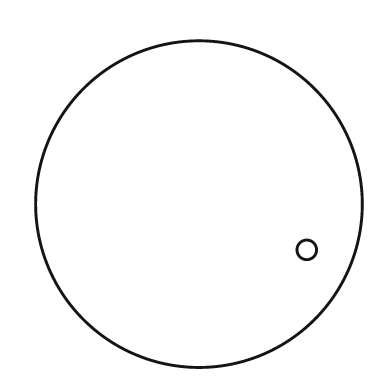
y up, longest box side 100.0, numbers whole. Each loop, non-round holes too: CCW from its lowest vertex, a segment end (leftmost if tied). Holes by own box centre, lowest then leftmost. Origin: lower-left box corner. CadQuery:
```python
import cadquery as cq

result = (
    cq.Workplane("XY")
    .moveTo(50.0, 50.0)
    .circle(50.0)
    .moveTo(83.0, 36.0)
    .circle(3.0)
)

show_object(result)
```